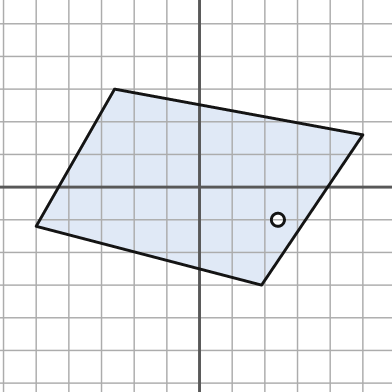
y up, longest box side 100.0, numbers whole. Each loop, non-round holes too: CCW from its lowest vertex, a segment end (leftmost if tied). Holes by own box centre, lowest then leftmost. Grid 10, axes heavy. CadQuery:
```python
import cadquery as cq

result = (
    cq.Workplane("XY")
    .moveTo(19.0, -30.0)
    .lineTo(50.0, 16.0)
    .lineTo(-26.0, 30.0)
    .lineTo(-50.0, -12.0)
    .close()
    .moveTo(24.0, -10.0)
    .circle(2.0)
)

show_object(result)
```